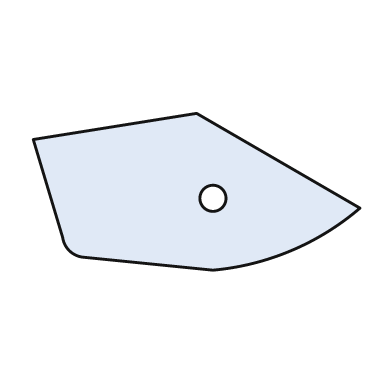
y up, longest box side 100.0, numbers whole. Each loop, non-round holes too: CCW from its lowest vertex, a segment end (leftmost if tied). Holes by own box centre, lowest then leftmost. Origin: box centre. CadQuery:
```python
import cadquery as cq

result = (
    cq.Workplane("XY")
    .moveTo(5.0, -24.0)
    .threePointArc((29.0, -18.0), (50.0, -5.0))
    .lineTo(0.0, 24.0)
    .lineTo(-50.0, 16.0)
    .lineTo(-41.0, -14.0)
    .threePointArc((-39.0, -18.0), (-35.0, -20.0))
    .close()
    .moveTo(5.0, -2.0)
    .circle(4.0)
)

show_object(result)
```